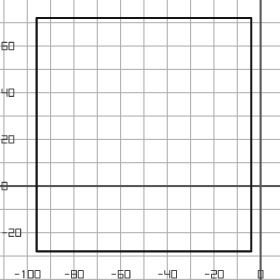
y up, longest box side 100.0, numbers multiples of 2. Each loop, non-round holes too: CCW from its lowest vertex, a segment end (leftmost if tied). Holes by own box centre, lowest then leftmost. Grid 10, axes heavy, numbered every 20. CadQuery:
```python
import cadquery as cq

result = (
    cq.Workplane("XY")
    .moveTo(-96.0, -28.0)
    .lineTo(-4.0, -28.0)
    .lineTo(-4.0, 72.0)
    .lineTo(-96.0, 72.0)
    .close()
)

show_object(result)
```